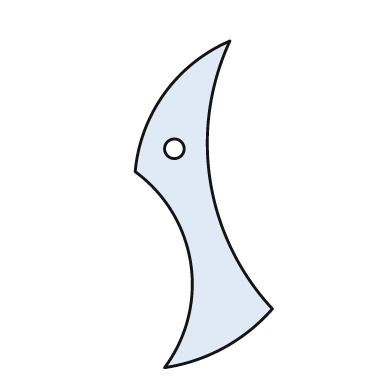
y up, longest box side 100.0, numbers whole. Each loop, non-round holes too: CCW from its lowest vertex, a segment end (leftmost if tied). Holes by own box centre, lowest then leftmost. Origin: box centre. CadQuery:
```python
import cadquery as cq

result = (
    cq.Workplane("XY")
    .moveTo(-12.0, -50.0)
    .threePointArc((6.0, -44.0), (21.0, -32.0))
    .threePointArc((2.0, 7.0), (8.0, 50.0))
    .threePointArc((-12.0, 34.0), (-21.0, 10.0))
    .threePointArc((-4.0, -18.0), (-12.0, -50.0))
    .close()
    .moveTo(-9.0, 17.0)
    .circle(3.0)
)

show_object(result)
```